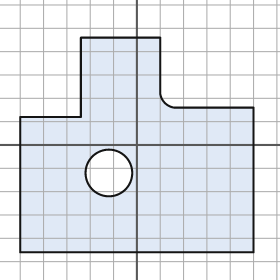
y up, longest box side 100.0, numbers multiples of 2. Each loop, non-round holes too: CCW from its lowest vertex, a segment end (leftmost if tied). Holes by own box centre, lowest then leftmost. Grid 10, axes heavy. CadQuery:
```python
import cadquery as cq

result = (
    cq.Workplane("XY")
    .moveTo(-50.0, -46.0)
    .lineTo(50.0, -46.0)
    .lineTo(50.0, 16.0)
    .lineTo(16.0, 16.0)
    .threePointArc((12.0, 18.0), (10.0, 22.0))
    .lineTo(10.0, 46.0)
    .lineTo(-24.0, 46.0)
    .lineTo(-24.0, 12.0)
    .lineTo(-50.0, 12.0)
    .close()
    .moveTo(-12.0, -12.0)
    .circle(10.0)
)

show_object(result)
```